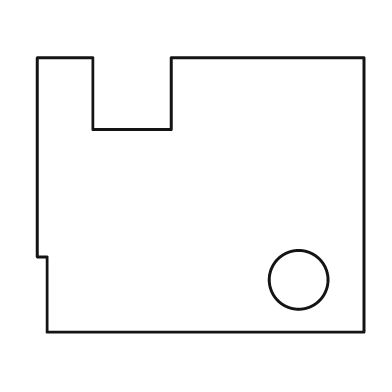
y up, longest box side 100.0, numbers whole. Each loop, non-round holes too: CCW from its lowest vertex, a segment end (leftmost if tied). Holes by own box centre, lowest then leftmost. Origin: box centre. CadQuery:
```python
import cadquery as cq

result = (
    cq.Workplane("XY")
    .moveTo(-47.0, -42.0)
    .lineTo(50.0, -42.0)
    .lineTo(50.0, 42.0)
    .lineTo(-9.0, 42.0)
    .lineTo(-9.0, 20.0)
    .lineTo(-33.0, 20.0)
    .lineTo(-33.0, 42.0)
    .lineTo(-50.0, 42.0)
    .lineTo(-50.0, -19.0)
    .lineTo(-47.0, -19.0)
    .close()
    .moveTo(30.0, -26.0)
    .circle(9.0)
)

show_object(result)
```